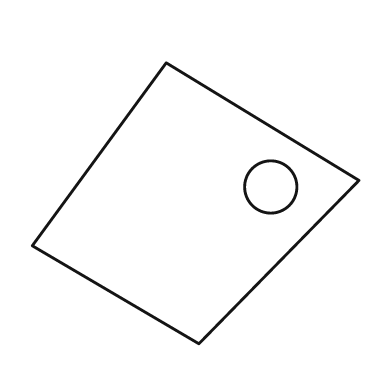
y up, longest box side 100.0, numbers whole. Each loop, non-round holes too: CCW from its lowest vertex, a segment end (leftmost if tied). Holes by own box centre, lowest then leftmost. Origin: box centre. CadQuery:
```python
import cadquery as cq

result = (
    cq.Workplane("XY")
    .moveTo(1.0, -43.0)
    .lineTo(50.0, 7.0)
    .lineTo(-9.0, 43.0)
    .lineTo(-50.0, -13.0)
    .close()
    .moveTo(23.0, 5.0)
    .circle(8.0)
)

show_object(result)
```